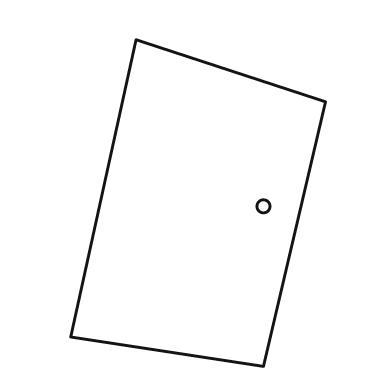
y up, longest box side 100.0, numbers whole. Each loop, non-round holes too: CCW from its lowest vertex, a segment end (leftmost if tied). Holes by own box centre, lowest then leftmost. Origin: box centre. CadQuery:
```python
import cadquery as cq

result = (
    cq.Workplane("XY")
    .moveTo(20.0, -50.0)
    .lineTo(39.0, 31.0)
    .lineTo(-19.0, 50.0)
    .lineTo(-39.0, -41.0)
    .close()
    .moveTo(20.0, -1.0)
    .circle(2.0)
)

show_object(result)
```